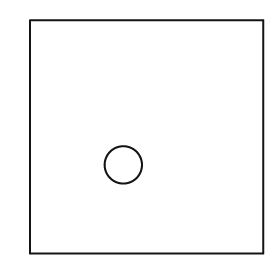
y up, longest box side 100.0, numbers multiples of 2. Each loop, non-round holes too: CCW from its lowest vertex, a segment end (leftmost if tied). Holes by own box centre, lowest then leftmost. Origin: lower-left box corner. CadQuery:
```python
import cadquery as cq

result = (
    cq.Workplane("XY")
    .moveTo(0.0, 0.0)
    .lineTo(100.0, 0.0)
    .lineTo(100.0, 100.0)
    .lineTo(0.0, 100.0)
    .close()
    .moveTo(40.0, 38.0)
    .circle(8.0)
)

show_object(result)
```